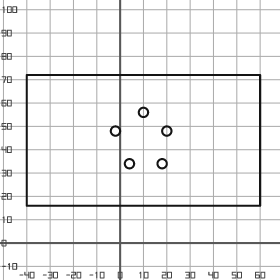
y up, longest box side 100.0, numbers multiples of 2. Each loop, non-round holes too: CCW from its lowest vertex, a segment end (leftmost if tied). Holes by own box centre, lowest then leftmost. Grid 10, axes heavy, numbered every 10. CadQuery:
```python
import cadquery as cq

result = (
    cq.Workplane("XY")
    .moveTo(-40.0, 16.0)
    .lineTo(60.0, 16.0)
    .lineTo(60.0, 72.0)
    .lineTo(-40.0, 72.0)
    .close()
    .moveTo(4.0, 34.0)
    .circle(2.0)
    .moveTo(18.0, 34.0)
    .circle(2.0)
    .moveTo(-2.0, 48.0)
    .circle(2.0)
    .moveTo(20.0, 48.0)
    .circle(2.0)
    .moveTo(10.0, 56.0)
    .circle(2.0)
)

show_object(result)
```